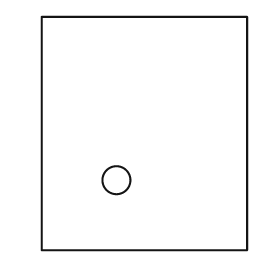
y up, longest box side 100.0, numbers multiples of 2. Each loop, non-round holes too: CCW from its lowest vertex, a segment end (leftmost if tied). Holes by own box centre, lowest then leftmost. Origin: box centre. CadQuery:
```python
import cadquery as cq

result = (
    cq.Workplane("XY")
    .moveTo(-44.0, -50.0)
    .lineTo(44.0, -50.0)
    .lineTo(44.0, 50.0)
    .lineTo(-44.0, 50.0)
    .close()
    .moveTo(-12.0, -20.0)
    .circle(6.0)
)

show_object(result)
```